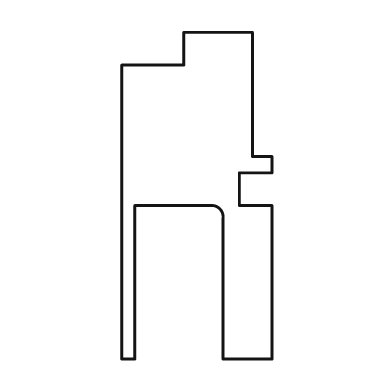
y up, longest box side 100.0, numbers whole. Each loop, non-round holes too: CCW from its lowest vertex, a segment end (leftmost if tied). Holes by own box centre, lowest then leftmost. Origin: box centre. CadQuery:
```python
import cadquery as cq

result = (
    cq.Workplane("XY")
    .moveTo(-23.0, -50.0)
    .lineTo(-19.0, -50.0)
    .lineTo(-19.0, -3.0)
    .lineTo(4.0, -3.0)
    .threePointArc((7.0, -4.0), (8.0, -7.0))
    .lineTo(8.0, -50.0)
    .lineTo(23.0, -50.0)
    .lineTo(23.0, -3.0)
    .lineTo(13.0, -3.0)
    .lineTo(13.0, 7.0)
    .lineTo(23.0, 7.0)
    .lineTo(23.0, 12.0)
    .lineTo(17.0, 12.0)
    .lineTo(17.0, 50.0)
    .lineTo(-4.0, 50.0)
    .lineTo(-4.0, 40.0)
    .lineTo(-23.0, 40.0)
    .close()
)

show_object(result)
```